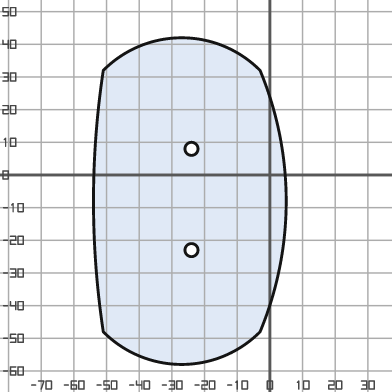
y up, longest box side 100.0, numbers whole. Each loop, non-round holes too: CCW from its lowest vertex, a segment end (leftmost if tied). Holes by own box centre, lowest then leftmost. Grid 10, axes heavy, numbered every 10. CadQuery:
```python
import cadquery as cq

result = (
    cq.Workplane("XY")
    .moveTo(-51.0, -48.0)
    .threePointArc((-27.0, -58.0), (-3.0, -48.0))
    .threePointArc((5.0, -8.0), (-3.0, 32.0))
    .threePointArc((-27.0, 42.0), (-51.0, 32.0))
    .threePointArc((-54.0, -8.0), (-51.0, -48.0))
    .close()
    .moveTo(-24.0, -23.0)
    .circle(2.0)
    .moveTo(-24.0, 8.0)
    .circle(2.0)
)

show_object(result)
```